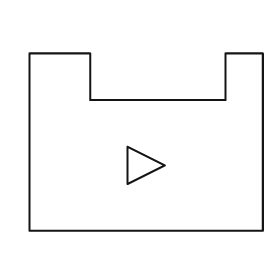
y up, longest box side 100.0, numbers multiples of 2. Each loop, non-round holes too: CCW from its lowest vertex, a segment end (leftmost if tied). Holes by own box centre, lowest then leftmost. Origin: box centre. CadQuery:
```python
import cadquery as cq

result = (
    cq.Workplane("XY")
    .moveTo(-50.0, -38.0)
    .lineTo(50.0, -38.0)
    .lineTo(50.0, 38.0)
    .lineTo(34.0, 38.0)
    .lineTo(34.0, 18.0)
    .lineTo(-24.0, 18.0)
    .lineTo(-24.0, 38.0)
    .lineTo(-50.0, 38.0)
    .close()
    .moveTo(-8.0, -18.0)
    .lineTo(8.0, -10.0)
    .lineTo(-8.0, -2.0)
    .close()
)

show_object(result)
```